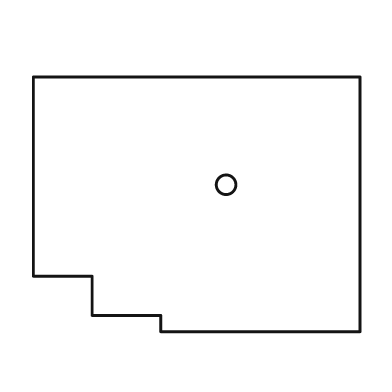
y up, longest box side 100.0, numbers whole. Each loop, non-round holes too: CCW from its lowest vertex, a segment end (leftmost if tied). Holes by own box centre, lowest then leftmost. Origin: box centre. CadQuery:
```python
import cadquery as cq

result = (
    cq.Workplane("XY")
    .moveTo(-11.0, -39.0)
    .lineTo(50.0, -39.0)
    .lineTo(50.0, 39.0)
    .lineTo(-50.0, 39.0)
    .lineTo(-50.0, -22.0)
    .lineTo(-32.0, -22.0)
    .lineTo(-32.0, -34.0)
    .lineTo(-11.0, -34.0)
    .close()
    .moveTo(9.0, 6.0)
    .circle(3.0)
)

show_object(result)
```